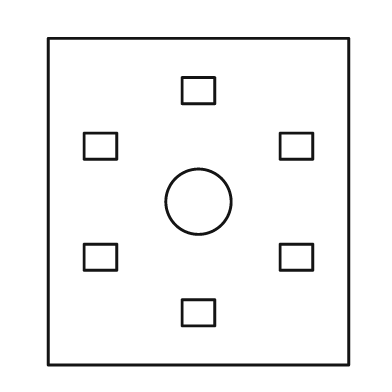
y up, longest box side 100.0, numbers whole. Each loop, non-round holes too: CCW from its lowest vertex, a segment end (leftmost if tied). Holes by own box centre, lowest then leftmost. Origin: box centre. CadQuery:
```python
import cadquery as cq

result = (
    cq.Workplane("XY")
    .moveTo(-46.0, -50.0)
    .lineTo(46.0, -50.0)
    .lineTo(46.0, 50.0)
    .lineTo(-46.0, 50.0)
    .close()
    .moveTo(-5.0, -38.0)
    .lineTo(5.0, -38.0)
    .lineTo(5.0, -30.0)
    .lineTo(-5.0, -30.0)
    .close()
    .moveTo(-35.0, -21.0)
    .lineTo(-25.0, -21.0)
    .lineTo(-25.0, -13.0)
    .lineTo(-35.0, -13.0)
    .close()
    .moveTo(25.0, -21.0)
    .lineTo(35.0, -21.0)
    .lineTo(35.0, -13.0)
    .lineTo(25.0, -13.0)
    .close()
    .moveTo(0.0, 0.0)
    .circle(10.0)
    .moveTo(-35.0, 13.0)
    .lineTo(-25.0, 13.0)
    .lineTo(-25.0, 21.0)
    .lineTo(-35.0, 21.0)
    .close()
    .moveTo(25.0, 13.0)
    .lineTo(35.0, 13.0)
    .lineTo(35.0, 21.0)
    .lineTo(25.0, 21.0)
    .close()
    .moveTo(-5.0, 30.0)
    .lineTo(5.0, 30.0)
    .lineTo(5.0, 38.0)
    .lineTo(-5.0, 38.0)
    .close()
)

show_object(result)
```